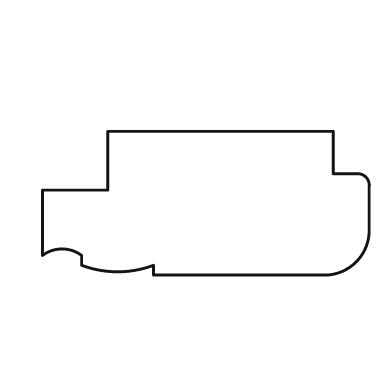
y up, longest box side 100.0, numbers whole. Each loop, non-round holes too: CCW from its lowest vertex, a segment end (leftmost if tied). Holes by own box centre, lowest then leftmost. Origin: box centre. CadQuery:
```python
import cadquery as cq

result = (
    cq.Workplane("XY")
    .moveTo(-16.0, -22.0)
    .lineTo(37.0, -22.0)
    .threePointArc((46.0, -18.0), (50.0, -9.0))
    .lineTo(50.0, 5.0)
    .threePointArc((49.0, 8.0), (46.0, 9.0))
    .lineTo(39.0, 9.0)
    .lineTo(39.0, 22.0)
    .lineTo(-30.0, 22.0)
    .lineTo(-30.0, 4.0)
    .lineTo(-50.0, 4.0)
    .lineTo(-50.0, -16.0)
    .threePointArc((-44.0, -14.0), (-38.0, -16.0))
    .lineTo(-38.0, -19.0)
    .threePointArc((-27.0, -21.0), (-16.0, -19.0))
    .close()
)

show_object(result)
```